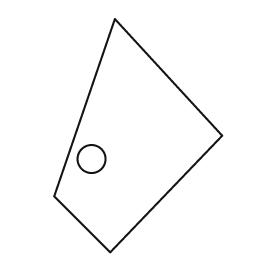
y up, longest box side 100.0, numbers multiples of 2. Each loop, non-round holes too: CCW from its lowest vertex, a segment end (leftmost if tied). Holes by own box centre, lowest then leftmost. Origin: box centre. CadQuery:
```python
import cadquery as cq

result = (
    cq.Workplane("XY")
    .moveTo(-12.0, -50.0)
    .lineTo(36.0, 0.0)
    .lineTo(-10.0, 50.0)
    .lineTo(-36.0, -26.0)
    .close()
    .moveTo(-20.0, -10.0)
    .circle(6.0)
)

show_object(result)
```